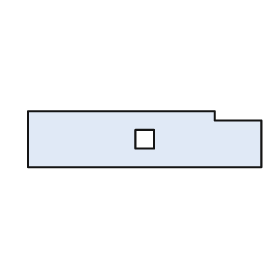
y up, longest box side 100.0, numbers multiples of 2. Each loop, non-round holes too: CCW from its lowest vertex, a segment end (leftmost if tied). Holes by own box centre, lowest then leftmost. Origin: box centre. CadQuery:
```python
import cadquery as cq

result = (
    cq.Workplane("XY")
    .moveTo(-50.0, -12.0)
    .lineTo(50.0, -12.0)
    .lineTo(50.0, 8.0)
    .lineTo(30.0, 8.0)
    .lineTo(30.0, 12.0)
    .lineTo(-50.0, 12.0)
    .close()
    .moveTo(-4.0, -4.0)
    .lineTo(4.0, -4.0)
    .lineTo(4.0, 4.0)
    .lineTo(-4.0, 4.0)
    .close()
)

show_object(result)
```